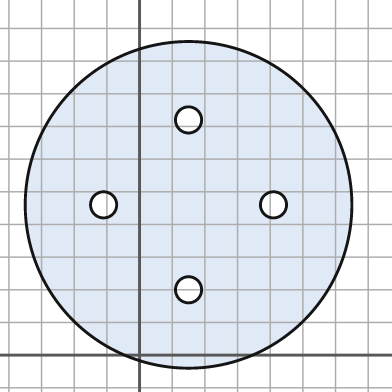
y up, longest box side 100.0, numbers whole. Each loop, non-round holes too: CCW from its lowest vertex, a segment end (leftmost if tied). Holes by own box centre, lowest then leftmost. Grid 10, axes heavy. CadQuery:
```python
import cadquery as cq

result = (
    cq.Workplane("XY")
    .moveTo(15.0, 46.0)
    .circle(50.0)
    .moveTo(15.0, 20.0)
    .circle(4.0)
    .moveTo(-11.0, 46.0)
    .circle(4.0)
    .moveTo(41.0, 46.0)
    .circle(4.0)
    .moveTo(15.0, 72.0)
    .circle(4.0)
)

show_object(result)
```